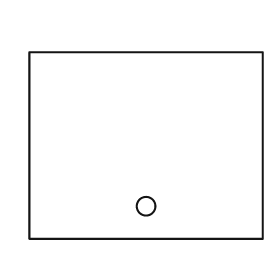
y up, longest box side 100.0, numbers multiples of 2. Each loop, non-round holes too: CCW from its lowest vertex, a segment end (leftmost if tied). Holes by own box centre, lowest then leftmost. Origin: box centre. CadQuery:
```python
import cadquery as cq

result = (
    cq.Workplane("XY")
    .moveTo(-50.0, -40.0)
    .lineTo(50.0, -40.0)
    .lineTo(50.0, 40.0)
    .lineTo(-50.0, 40.0)
    .close()
    .moveTo(0.0, -26.0)
    .circle(4.0)
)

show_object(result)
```